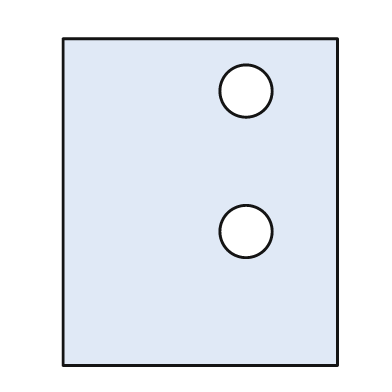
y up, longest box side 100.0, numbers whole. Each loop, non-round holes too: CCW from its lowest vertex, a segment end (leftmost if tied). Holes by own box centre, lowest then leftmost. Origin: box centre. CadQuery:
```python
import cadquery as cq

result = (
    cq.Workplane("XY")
    .moveTo(-42.0, -50.0)
    .lineTo(42.0, -50.0)
    .lineTo(42.0, 50.0)
    .lineTo(-42.0, 50.0)
    .close()
    .moveTo(14.0, -9.0)
    .circle(8.0)
    .moveTo(14.0, 34.0)
    .circle(8.0)
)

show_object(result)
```